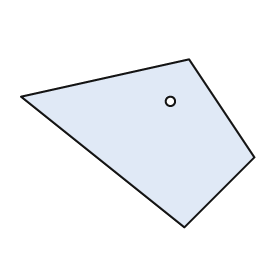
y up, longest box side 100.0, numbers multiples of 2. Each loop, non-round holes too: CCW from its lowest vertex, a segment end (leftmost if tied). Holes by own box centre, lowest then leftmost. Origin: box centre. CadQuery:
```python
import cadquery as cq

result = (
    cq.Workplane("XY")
    .moveTo(20.0, -36.0)
    .lineTo(50.0, -6.0)
    .lineTo(22.0, 36.0)
    .lineTo(-50.0, 20.0)
    .close()
    .moveTo(14.0, 18.0)
    .circle(2.0)
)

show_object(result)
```